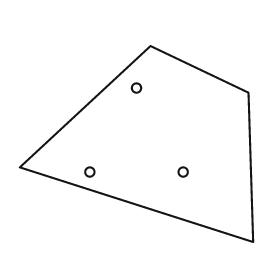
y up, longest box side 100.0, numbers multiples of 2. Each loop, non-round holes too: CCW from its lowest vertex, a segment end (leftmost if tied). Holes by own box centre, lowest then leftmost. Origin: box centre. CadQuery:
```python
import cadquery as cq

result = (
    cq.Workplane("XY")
    .moveTo(50.0, -42.0)
    .lineTo(48.0, 22.0)
    .lineTo(6.0, 42.0)
    .lineTo(-50.0, -10.0)
    .close()
    .moveTo(-20.0, -12.0)
    .circle(2.0)
    .moveTo(20.0, -12.0)
    .circle(2.0)
    .moveTo(0.0, 24.0)
    .circle(2.0)
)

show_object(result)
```